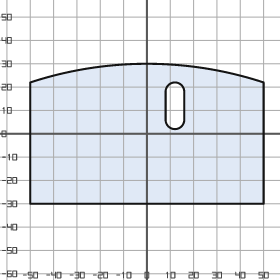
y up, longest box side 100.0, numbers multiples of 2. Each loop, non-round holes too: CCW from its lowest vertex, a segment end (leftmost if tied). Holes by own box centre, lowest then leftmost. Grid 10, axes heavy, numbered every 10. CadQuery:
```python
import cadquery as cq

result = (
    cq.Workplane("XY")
    .moveTo(-50.0, -30.0)
    .lineTo(50.0, -30.0)
    .lineTo(50.0, 22.0)
    .threePointArc((0.0, 30.0), (-50.0, 22.0))
    .close()
    .moveTo(8.0, 6.0)
    .threePointArc((12.0, 2.0), (16.0, 6.0))
    .lineTo(16.0, 18.0)
    .threePointArc((12.0, 22.0), (8.0, 18.0))
    .close()
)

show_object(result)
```